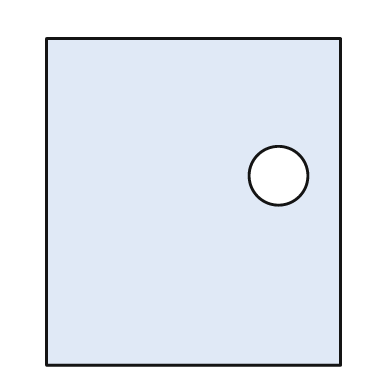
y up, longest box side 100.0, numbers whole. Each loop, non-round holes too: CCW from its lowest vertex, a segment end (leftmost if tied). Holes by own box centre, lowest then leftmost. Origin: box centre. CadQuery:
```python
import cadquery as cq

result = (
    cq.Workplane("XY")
    .moveTo(-45.0, -50.0)
    .lineTo(45.0, -50.0)
    .lineTo(45.0, 50.0)
    .lineTo(-45.0, 50.0)
    .close()
    .moveTo(26.0, 8.0)
    .circle(9.0)
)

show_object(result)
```